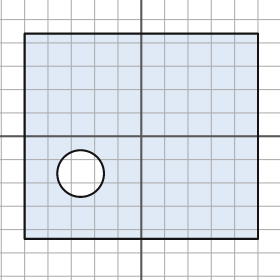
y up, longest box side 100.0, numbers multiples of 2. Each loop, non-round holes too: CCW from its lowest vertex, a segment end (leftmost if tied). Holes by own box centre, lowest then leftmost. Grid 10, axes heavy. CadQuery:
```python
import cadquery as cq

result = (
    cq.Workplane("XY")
    .moveTo(-50.0, -44.0)
    .lineTo(50.0, -44.0)
    .lineTo(50.0, 44.0)
    .lineTo(-50.0, 44.0)
    .close()
    .moveTo(-26.0, -16.0)
    .circle(10.0)
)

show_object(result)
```